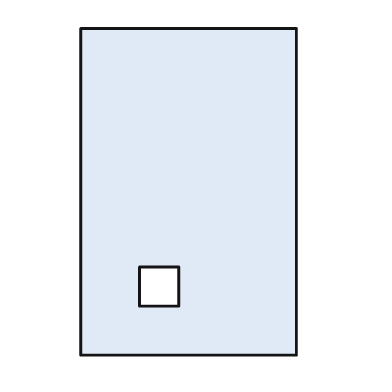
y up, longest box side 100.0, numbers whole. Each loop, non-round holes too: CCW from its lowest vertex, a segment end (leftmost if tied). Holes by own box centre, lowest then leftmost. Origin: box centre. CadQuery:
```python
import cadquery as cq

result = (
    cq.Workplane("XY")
    .moveTo(-33.0, -50.0)
    .lineTo(33.0, -50.0)
    .lineTo(33.0, 50.0)
    .lineTo(-33.0, 50.0)
    .close()
    .moveTo(-15.0, -35.0)
    .lineTo(-3.0, -35.0)
    .lineTo(-3.0, -23.0)
    .lineTo(-15.0, -23.0)
    .close()
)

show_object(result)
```